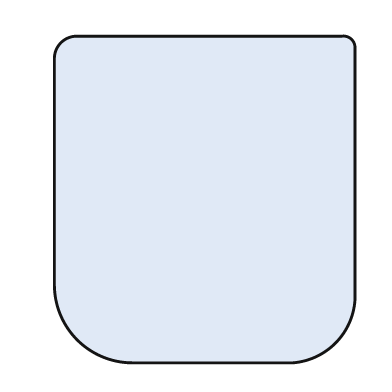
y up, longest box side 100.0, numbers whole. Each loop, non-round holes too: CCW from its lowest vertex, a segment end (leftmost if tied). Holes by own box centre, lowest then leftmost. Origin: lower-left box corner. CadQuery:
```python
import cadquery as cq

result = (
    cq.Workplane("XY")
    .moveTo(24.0, 0.0)
    .lineTo(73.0, 0.0)
    .threePointArc((86.0, 6.0), (92.0, 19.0))
    .lineTo(92.0, 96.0)
    .threePointArc((91.0, 99.0), (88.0, 100.0))
    .lineTo(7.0, 100.0)
    .threePointArc((2.0, 98.0), (0.0, 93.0))
    .lineTo(0.0, 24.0)
    .threePointArc((7.0, 7.0), (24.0, 0.0))
    .close()
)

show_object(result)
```